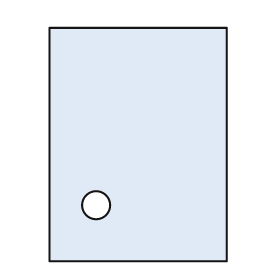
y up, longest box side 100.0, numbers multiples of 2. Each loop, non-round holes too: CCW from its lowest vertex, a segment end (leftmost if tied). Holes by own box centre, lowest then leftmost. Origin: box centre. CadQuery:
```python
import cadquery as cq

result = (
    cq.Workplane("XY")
    .moveTo(-38.0, -50.0)
    .lineTo(38.0, -50.0)
    .lineTo(38.0, 50.0)
    .lineTo(-38.0, 50.0)
    .close()
    .moveTo(-18.0, -26.0)
    .circle(6.0)
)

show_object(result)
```